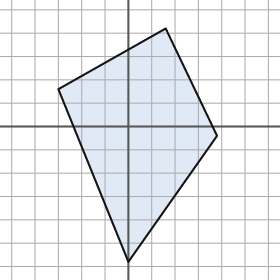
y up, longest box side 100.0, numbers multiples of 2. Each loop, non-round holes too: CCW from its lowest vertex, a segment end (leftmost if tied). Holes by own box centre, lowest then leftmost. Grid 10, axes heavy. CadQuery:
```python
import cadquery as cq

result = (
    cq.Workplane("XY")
    .moveTo(0.0, -58.0)
    .lineTo(38.0, -4.0)
    .lineTo(16.0, 42.0)
    .lineTo(-30.0, 16.0)
    .close()
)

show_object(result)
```